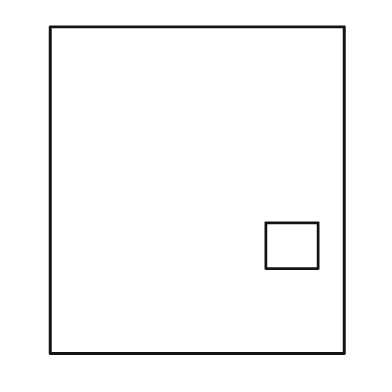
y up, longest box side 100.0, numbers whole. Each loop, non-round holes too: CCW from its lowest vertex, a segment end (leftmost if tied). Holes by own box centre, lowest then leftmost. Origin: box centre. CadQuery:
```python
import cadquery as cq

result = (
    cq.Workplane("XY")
    .moveTo(-45.0, -50.0)
    .lineTo(45.0, -50.0)
    .lineTo(45.0, 50.0)
    .lineTo(-45.0, 50.0)
    .close()
    .moveTo(21.0, -24.0)
    .lineTo(37.0, -24.0)
    .lineTo(37.0, -10.0)
    .lineTo(21.0, -10.0)
    .close()
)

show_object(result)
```